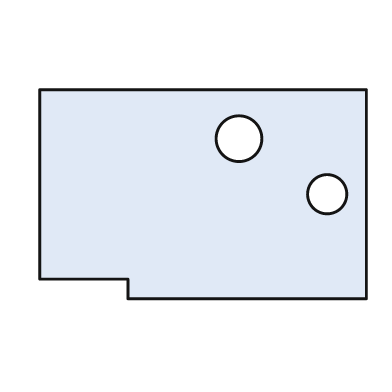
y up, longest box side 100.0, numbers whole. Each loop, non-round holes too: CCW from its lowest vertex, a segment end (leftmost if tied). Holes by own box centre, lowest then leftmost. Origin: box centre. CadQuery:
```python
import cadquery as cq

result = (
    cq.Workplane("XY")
    .moveTo(-23.0, -32.0)
    .lineTo(50.0, -32.0)
    .lineTo(50.0, 32.0)
    .lineTo(-50.0, 32.0)
    .lineTo(-50.0, -26.0)
    .lineTo(-23.0, -26.0)
    .close()
    .moveTo(38.0, 0.0)
    .circle(6.0)
    .moveTo(11.0, 17.0)
    .circle(7.0)
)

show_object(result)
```